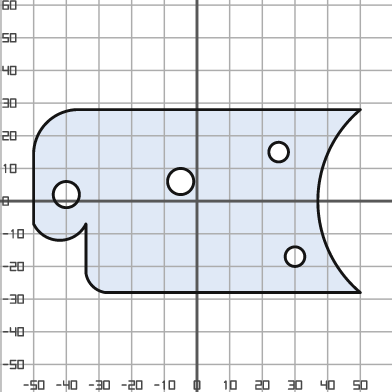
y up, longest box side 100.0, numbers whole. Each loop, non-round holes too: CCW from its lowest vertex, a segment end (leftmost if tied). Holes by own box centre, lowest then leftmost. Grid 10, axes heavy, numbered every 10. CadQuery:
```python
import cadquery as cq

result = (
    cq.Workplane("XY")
    .moveTo(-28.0, -28.0)
    .lineTo(50.0, -28.0)
    .threePointArc((37.0, 0.0), (50.0, 28.0))
    .lineTo(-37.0, 28.0)
    .threePointArc((-46.0, 24.0), (-50.0, 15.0))
    .lineTo(-50.0, -7.0)
    .threePointArc((-42.0, -12.0), (-34.0, -7.0))
    .lineTo(-34.0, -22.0)
    .threePointArc((-32.0, -26.0), (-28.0, -28.0))
    .close()
    .moveTo(30.0, -17.0)
    .circle(3.0)
    .moveTo(-40.0, 2.0)
    .circle(4.0)
    .moveTo(-5.0, 6.0)
    .circle(4.0)
    .moveTo(25.0, 15.0)
    .circle(3.0)
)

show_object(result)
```